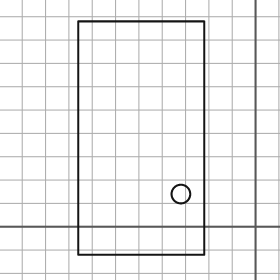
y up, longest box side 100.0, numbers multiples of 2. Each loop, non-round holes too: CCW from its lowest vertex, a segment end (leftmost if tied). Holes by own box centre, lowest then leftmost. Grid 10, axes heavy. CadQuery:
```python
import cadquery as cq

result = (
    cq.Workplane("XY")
    .moveTo(-76.0, -12.0)
    .lineTo(-22.0, -12.0)
    .lineTo(-22.0, 88.0)
    .lineTo(-76.0, 88.0)
    .close()
    .moveTo(-32.0, 14.0)
    .circle(4.0)
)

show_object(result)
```